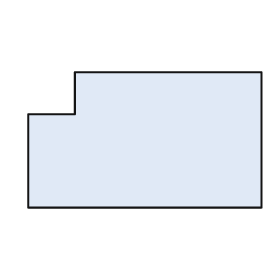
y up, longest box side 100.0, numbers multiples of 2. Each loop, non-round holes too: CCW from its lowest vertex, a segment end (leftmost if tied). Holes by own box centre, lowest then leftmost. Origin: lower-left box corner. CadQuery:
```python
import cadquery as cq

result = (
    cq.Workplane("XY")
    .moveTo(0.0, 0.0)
    .lineTo(100.0, 0.0)
    .lineTo(100.0, 58.0)
    .lineTo(20.0, 58.0)
    .lineTo(20.0, 40.0)
    .lineTo(0.0, 40.0)
    .close()
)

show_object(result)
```